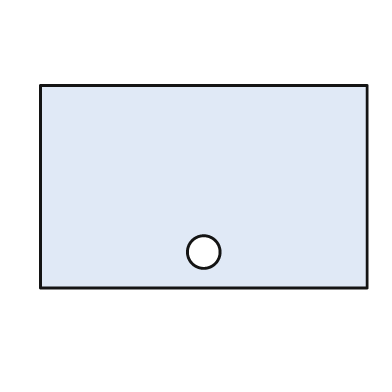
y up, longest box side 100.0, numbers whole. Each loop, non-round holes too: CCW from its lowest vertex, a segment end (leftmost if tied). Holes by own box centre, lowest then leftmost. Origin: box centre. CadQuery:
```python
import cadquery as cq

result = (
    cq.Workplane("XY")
    .moveTo(-50.0, -31.0)
    .lineTo(50.0, -31.0)
    .lineTo(50.0, 31.0)
    .lineTo(-50.0, 31.0)
    .close()
    .moveTo(0.0, -20.0)
    .circle(5.0)
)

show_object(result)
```